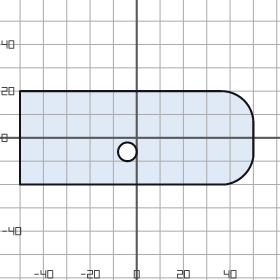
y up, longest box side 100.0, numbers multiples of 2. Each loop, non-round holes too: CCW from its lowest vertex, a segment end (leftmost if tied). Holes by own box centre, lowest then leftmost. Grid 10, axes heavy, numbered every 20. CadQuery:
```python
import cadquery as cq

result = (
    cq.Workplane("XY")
    .moveTo(-50.0, -20.0)
    .lineTo(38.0, -20.0)
    .threePointArc((46.0, -16.0), (50.0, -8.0))
    .lineTo(50.0, 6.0)
    .threePointArc((46.0, 16.0), (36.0, 20.0))
    .lineTo(-50.0, 20.0)
    .close()
    .moveTo(-4.0, -6.0)
    .circle(4.0)
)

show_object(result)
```